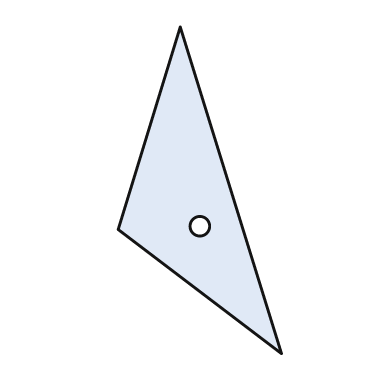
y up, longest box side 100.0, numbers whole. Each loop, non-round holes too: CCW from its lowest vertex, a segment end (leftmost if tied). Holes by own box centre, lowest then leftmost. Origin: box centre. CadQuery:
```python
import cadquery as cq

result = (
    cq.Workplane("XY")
    .moveTo(25.0, -50.0)
    .lineTo(-6.0, 50.0)
    .lineTo(-25.0, -12.0)
    .close()
    .moveTo(0.0, -11.0)
    .circle(3.0)
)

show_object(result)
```